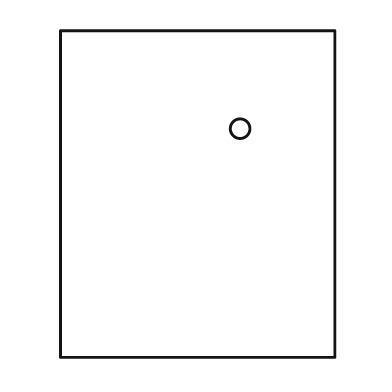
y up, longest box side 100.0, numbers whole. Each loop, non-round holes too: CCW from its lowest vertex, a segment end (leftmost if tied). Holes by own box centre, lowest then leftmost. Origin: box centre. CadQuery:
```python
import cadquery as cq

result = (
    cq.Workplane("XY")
    .moveTo(-42.0, -50.0)
    .lineTo(42.0, -50.0)
    .lineTo(42.0, 50.0)
    .lineTo(-42.0, 50.0)
    .close()
    .moveTo(13.0, 20.0)
    .circle(3.0)
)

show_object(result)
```